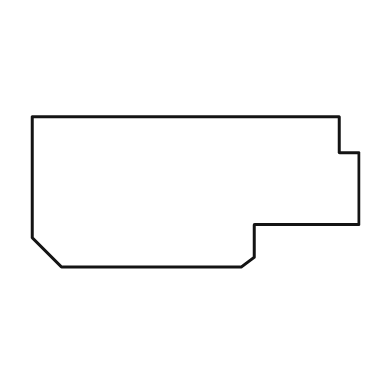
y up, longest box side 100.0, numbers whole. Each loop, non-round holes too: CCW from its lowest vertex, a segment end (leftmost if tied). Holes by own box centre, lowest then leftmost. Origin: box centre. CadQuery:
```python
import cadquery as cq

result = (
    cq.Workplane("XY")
    .moveTo(-41.0, -23.0)
    .lineTo(14.0, -23.0)
    .lineTo(18.0, -20.0)
    .lineTo(18.0, -10.0)
    .lineTo(50.0, -10.0)
    .lineTo(50.0, 12.0)
    .lineTo(44.0, 12.0)
    .lineTo(44.0, 23.0)
    .lineTo(-50.0, 23.0)
    .lineTo(-50.0, -14.0)
    .close()
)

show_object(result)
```